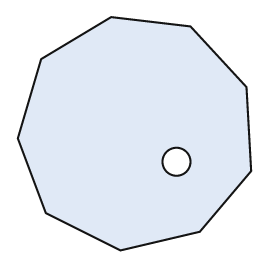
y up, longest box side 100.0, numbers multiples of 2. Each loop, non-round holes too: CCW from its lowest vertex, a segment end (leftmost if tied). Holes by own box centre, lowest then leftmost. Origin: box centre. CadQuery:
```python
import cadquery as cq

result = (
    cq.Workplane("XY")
    .moveTo(-6.0, -50.0)
    .lineTo(28.0, -42.0)
    .lineTo(50.0, -16.0)
    .lineTo(48.0, 20.0)
    .lineTo(24.0, 46.0)
    .lineTo(-10.0, 50.0)
    .lineTo(-40.0, 32.0)
    .lineTo(-50.0, -2.0)
    .lineTo(-38.0, -34.0)
    .close()
    .moveTo(18.0, -12.0)
    .circle(6.0)
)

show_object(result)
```